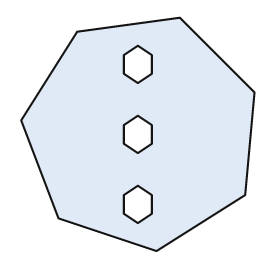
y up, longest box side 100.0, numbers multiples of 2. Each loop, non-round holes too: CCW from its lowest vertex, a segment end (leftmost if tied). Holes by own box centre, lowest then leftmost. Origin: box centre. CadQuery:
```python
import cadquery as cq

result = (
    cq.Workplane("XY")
    .moveTo(8.0, -50.0)
    .lineTo(46.0, -26.0)
    .lineTo(50.0, 18.0)
    .lineTo(18.0, 50.0)
    .lineTo(-26.0, 44.0)
    .lineTo(-50.0, 6.0)
    .lineTo(-34.0, -36.0)
    .close()
    .moveTo(0.0, -38.0)
    .lineTo(6.0, -34.0)
    .lineTo(6.0, -26.0)
    .lineTo(0.0, -22.0)
    .lineTo(-6.0, -26.0)
    .lineTo(-6.0, -34.0)
    .close()
    .moveTo(0.0, -8.0)
    .lineTo(6.0, -4.0)
    .lineTo(6.0, 4.0)
    .lineTo(0.0, 8.0)
    .lineTo(-6.0, 4.0)
    .lineTo(-6.0, -4.0)
    .close()
    .moveTo(0.0, 22.0)
    .lineTo(6.0, 26.0)
    .lineTo(6.0, 34.0)
    .lineTo(0.0, 38.0)
    .lineTo(-6.0, 34.0)
    .lineTo(-6.0, 26.0)
    .close()
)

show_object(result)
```